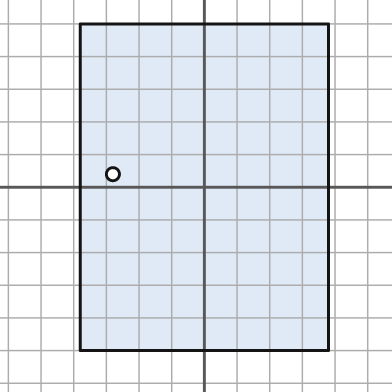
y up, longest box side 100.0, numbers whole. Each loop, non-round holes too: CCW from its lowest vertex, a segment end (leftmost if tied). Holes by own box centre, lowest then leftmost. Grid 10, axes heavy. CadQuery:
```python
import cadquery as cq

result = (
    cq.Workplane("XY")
    .moveTo(-38.0, -50.0)
    .lineTo(38.0, -50.0)
    .lineTo(38.0, 50.0)
    .lineTo(-38.0, 50.0)
    .close()
    .moveTo(-28.0, 4.0)
    .circle(2.0)
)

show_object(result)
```